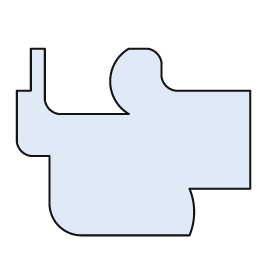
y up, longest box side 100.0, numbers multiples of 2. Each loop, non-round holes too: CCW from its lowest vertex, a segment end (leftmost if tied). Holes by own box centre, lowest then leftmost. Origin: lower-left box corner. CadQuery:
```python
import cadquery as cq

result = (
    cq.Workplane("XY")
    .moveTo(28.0, 0.0)
    .lineTo(74.0, 0.0)
    .threePointArc((76.0, 10.0), (74.0, 20.0))
    .lineTo(100.0, 20.0)
    .lineTo(100.0, 62.0)
    .lineTo(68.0, 62.0)
    .threePointArc((64.0, 64.0), (62.0, 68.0))
    .lineTo(62.0, 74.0)
    .threePointArc((60.0, 78.0), (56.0, 80.0))
    .lineTo(48.0, 80.0)
    .threePointArc((40.0, 66.0), (48.0, 52.0))
    .lineTo(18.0, 52.0)
    .threePointArc((14.0, 54.0), (12.0, 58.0))
    .lineTo(12.0, 80.0)
    .lineTo(6.0, 80.0)
    .lineTo(6.0, 62.0)
    .lineTo(0.0, 62.0)
    .lineTo(0.0, 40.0)
    .threePointArc((2.0, 36.0), (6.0, 34.0))
    .lineTo(14.0, 34.0)
    .lineTo(14.0, 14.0)
    .threePointArc((18.0, 4.0), (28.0, 0.0))
    .close()
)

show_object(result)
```